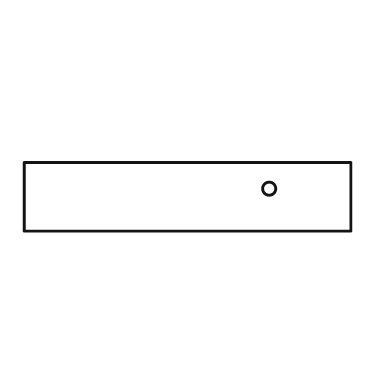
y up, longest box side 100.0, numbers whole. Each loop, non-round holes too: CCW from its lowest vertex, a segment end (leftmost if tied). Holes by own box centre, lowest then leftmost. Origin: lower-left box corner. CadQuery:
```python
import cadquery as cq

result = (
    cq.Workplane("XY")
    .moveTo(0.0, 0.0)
    .lineTo(100.0, 0.0)
    .lineTo(100.0, 21.0)
    .lineTo(0.0, 21.0)
    .close()
    .moveTo(75.0, 13.0)
    .circle(2.0)
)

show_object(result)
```